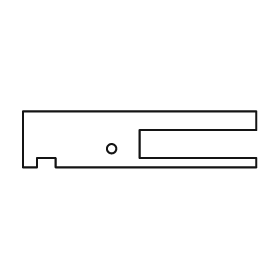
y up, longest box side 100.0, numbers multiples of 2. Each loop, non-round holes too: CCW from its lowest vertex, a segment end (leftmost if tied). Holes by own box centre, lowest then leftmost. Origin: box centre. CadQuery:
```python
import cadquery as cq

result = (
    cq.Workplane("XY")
    .moveTo(-50.0, -12.0)
    .lineTo(-44.0, -12.0)
    .lineTo(-44.0, -8.0)
    .lineTo(-36.0, -8.0)
    .lineTo(-36.0, -12.0)
    .lineTo(50.0, -12.0)
    .lineTo(50.0, -8.0)
    .lineTo(0.0, -8.0)
    .lineTo(0.0, 4.0)
    .lineTo(50.0, 4.0)
    .lineTo(50.0, 12.0)
    .lineTo(-50.0, 12.0)
    .close()
    .moveTo(-12.0, -4.0)
    .circle(2.0)
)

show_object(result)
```